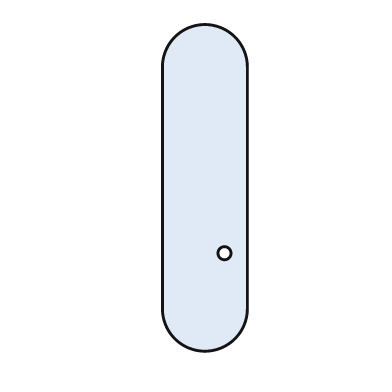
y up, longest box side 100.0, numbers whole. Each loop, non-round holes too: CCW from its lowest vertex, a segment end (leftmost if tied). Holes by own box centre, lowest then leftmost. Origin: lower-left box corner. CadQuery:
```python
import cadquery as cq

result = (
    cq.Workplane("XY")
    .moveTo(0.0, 13.0)
    .threePointArc((13.0, 0.0), (26.0, 13.0))
    .lineTo(26.0, 87.0)
    .threePointArc((13.0, 100.0), (0.0, 87.0))
    .close()
    .moveTo(19.0, 30.0)
    .circle(2.0)
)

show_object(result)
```